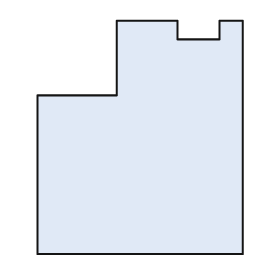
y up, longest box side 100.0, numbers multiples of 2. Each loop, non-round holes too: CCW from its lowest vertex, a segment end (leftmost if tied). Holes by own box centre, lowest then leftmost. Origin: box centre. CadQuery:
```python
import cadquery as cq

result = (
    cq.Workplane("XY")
    .moveTo(-44.0, -50.0)
    .lineTo(44.0, -50.0)
    .lineTo(44.0, 50.0)
    .lineTo(34.0, 50.0)
    .lineTo(34.0, 42.0)
    .lineTo(16.0, 42.0)
    .lineTo(16.0, 50.0)
    .lineTo(-10.0, 50.0)
    .lineTo(-10.0, 18.0)
    .lineTo(-44.0, 18.0)
    .close()
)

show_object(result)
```